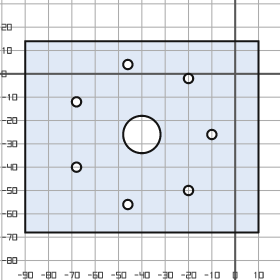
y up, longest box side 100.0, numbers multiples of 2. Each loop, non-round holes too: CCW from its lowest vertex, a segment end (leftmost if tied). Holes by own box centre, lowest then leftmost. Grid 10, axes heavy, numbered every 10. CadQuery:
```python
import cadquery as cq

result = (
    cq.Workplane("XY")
    .moveTo(-90.0, -68.0)
    .lineTo(10.0, -68.0)
    .lineTo(10.0, 14.0)
    .lineTo(-90.0, 14.0)
    .close()
    .moveTo(-46.0, -56.0)
    .circle(2.0)
    .moveTo(-20.0, -50.0)
    .circle(2.0)
    .moveTo(-68.0, -40.0)
    .circle(2.0)
    .moveTo(-40.0, -26.0)
    .circle(8.0)
    .moveTo(-10.0, -26.0)
    .circle(2.0)
    .moveTo(-68.0, -12.0)
    .circle(2.0)
    .moveTo(-20.0, -2.0)
    .circle(2.0)
    .moveTo(-46.0, 4.0)
    .circle(2.0)
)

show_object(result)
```